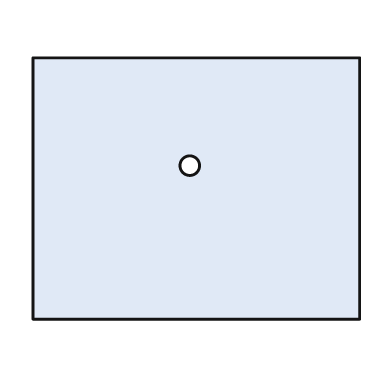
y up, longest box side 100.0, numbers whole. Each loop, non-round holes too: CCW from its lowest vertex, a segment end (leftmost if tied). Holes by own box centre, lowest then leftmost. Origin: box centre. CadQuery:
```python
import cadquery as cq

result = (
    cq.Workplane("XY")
    .moveTo(-50.0, -40.0)
    .lineTo(50.0, -40.0)
    .lineTo(50.0, 40.0)
    .lineTo(-50.0, 40.0)
    .close()
    .moveTo(-2.0, 7.0)
    .circle(3.0)
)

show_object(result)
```